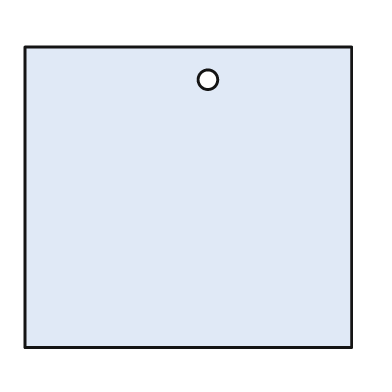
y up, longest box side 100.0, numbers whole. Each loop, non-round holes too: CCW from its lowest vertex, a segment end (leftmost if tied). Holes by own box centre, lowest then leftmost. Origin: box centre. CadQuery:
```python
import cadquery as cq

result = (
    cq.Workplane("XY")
    .moveTo(-50.0, -46.0)
    .lineTo(50.0, -46.0)
    .lineTo(50.0, 46.0)
    .lineTo(-50.0, 46.0)
    .close()
    .moveTo(6.0, 36.0)
    .circle(3.0)
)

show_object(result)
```